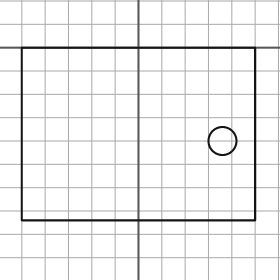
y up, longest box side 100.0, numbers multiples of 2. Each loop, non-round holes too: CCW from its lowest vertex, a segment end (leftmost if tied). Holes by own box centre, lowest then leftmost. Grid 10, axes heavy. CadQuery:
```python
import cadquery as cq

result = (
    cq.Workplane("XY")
    .moveTo(-50.0, -74.0)
    .lineTo(50.0, -74.0)
    .lineTo(50.0, 0.0)
    .lineTo(-50.0, 0.0)
    .close()
    .moveTo(36.0, -40.0)
    .circle(6.0)
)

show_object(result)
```